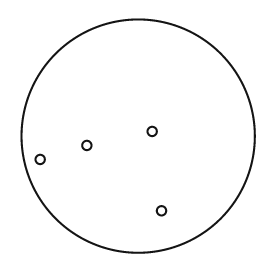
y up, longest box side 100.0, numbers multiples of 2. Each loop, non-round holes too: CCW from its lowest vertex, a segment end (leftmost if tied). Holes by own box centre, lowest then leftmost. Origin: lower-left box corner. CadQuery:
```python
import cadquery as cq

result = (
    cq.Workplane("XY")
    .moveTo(50.0, 50.0)
    .circle(50.0)
    .moveTo(60.0, 18.0)
    .circle(2.0)
    .moveTo(8.0, 40.0)
    .circle(2.0)
    .moveTo(28.0, 46.0)
    .circle(2.0)
    .moveTo(56.0, 52.0)
    .circle(2.0)
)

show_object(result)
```